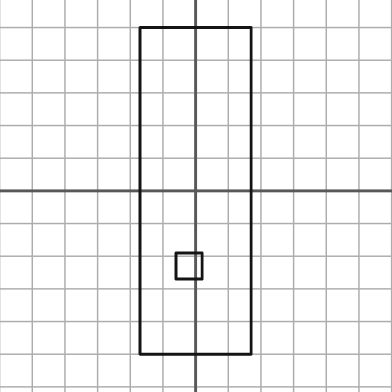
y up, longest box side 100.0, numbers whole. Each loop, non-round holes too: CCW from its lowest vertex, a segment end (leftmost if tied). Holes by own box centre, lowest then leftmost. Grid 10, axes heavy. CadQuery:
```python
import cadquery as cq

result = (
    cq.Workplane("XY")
    .moveTo(-17.0, -50.0)
    .lineTo(17.0, -50.0)
    .lineTo(17.0, 50.0)
    .lineTo(-17.0, 50.0)
    .close()
    .moveTo(-6.0, -27.0)
    .lineTo(2.0, -27.0)
    .lineTo(2.0, -19.0)
    .lineTo(-6.0, -19.0)
    .close()
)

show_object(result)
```